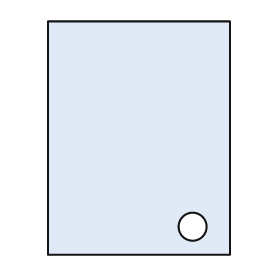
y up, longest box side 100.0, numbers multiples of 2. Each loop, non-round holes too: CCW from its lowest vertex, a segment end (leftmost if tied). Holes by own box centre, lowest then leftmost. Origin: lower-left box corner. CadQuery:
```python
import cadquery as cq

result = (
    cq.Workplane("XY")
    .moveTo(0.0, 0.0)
    .lineTo(78.0, 0.0)
    .lineTo(78.0, 100.0)
    .lineTo(0.0, 100.0)
    .close()
    .moveTo(62.0, 12.0)
    .circle(6.0)
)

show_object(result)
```